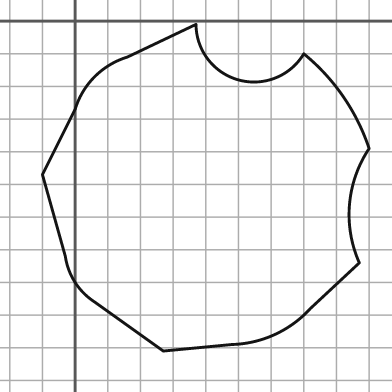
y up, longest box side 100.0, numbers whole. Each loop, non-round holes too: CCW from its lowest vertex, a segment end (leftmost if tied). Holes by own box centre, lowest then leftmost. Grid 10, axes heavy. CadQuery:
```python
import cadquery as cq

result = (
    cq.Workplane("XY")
    .moveTo(27.0, -101.0)
    .lineTo(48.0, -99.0)
    .threePointArc((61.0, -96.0), (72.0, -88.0))
    .lineTo(87.0, -74.0)
    .threePointArc((84.0, -56.0), (90.0, -39.0))
    .threePointArc((82.0, -23.0), (70.0, -10.0))
    .threePointArc((50.0, -18.0), (37.0, -1.0))
    .lineTo(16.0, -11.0)
    .threePointArc((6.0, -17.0), (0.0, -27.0))
    .lineTo(-10.0, -47.0)
    .lineTo(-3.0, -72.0)
    .threePointArc((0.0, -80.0), (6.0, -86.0))
    .close()
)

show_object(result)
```